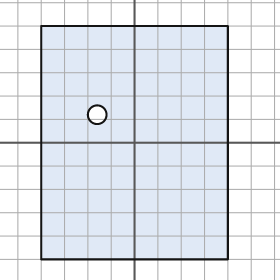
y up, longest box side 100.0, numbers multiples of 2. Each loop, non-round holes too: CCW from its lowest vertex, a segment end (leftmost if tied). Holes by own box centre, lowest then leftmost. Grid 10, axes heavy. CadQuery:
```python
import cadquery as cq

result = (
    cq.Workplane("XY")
    .moveTo(-40.0, -50.0)
    .lineTo(40.0, -50.0)
    .lineTo(40.0, 50.0)
    .lineTo(-40.0, 50.0)
    .close()
    .moveTo(-16.0, 12.0)
    .circle(4.0)
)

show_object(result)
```